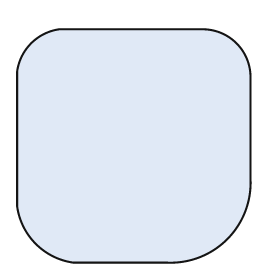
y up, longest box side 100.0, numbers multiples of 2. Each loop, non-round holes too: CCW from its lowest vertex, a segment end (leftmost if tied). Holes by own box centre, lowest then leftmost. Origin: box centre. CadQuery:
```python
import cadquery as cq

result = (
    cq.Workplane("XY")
    .moveTo(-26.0, -50.0)
    .lineTo(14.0, -50.0)
    .threePointArc((40.0, -40.0), (50.0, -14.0))
    .lineTo(50.0, 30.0)
    .threePointArc((44.0, 44.0), (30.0, 50.0))
    .lineTo(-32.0, 50.0)
    .threePointArc((-44.0, 44.0), (-50.0, 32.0))
    .lineTo(-50.0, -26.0)
    .threePointArc((-42.0, -42.0), (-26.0, -50.0))
    .close()
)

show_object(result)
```